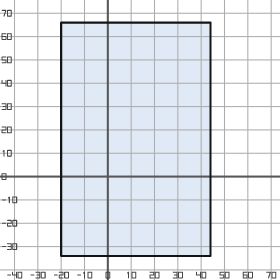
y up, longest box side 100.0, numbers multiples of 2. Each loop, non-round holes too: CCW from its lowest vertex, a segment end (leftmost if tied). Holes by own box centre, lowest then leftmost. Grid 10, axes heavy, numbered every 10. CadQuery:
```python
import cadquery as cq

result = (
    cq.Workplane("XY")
    .moveTo(-20.0, -34.0)
    .lineTo(44.0, -34.0)
    .lineTo(44.0, 66.0)
    .lineTo(-20.0, 66.0)
    .close()
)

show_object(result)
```